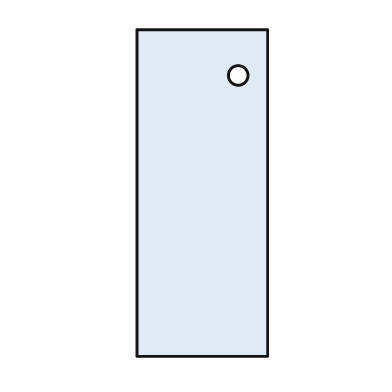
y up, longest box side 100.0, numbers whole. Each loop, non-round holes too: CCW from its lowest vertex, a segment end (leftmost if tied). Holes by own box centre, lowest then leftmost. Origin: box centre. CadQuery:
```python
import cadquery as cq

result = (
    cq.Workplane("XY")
    .moveTo(-20.0, -50.0)
    .lineTo(20.0, -50.0)
    .lineTo(20.0, 50.0)
    .lineTo(-20.0, 50.0)
    .close()
    .moveTo(11.0, 36.0)
    .circle(3.0)
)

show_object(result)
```